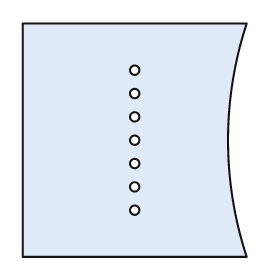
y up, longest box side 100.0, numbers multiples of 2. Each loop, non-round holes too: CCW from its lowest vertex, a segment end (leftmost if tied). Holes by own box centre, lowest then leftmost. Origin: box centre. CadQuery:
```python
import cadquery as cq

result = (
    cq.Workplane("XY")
    .moveTo(-48.0, -50.0)
    .lineTo(48.0, -50.0)
    .threePointArc((40.0, 0.0), (48.0, 50.0))
    .lineTo(-48.0, 50.0)
    .close()
    .moveTo(0.0, -30.0)
    .circle(2.0)
    .moveTo(0.0, -20.0)
    .circle(2.0)
    .moveTo(0.0, -10.0)
    .circle(2.0)
    .moveTo(0.0, 0.0)
    .circle(2.0)
    .moveTo(0.0, 10.0)
    .circle(2.0)
    .moveTo(0.0, 20.0)
    .circle(2.0)
    .moveTo(0.0, 30.0)
    .circle(2.0)
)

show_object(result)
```